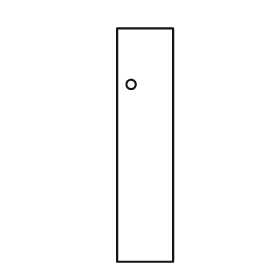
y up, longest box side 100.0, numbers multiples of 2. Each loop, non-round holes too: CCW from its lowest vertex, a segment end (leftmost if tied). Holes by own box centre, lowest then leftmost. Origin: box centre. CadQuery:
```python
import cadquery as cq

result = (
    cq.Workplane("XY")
    .moveTo(-12.0, -50.0)
    .lineTo(12.0, -50.0)
    .lineTo(12.0, 50.0)
    .lineTo(-12.0, 50.0)
    .close()
    .moveTo(-6.0, 26.0)
    .circle(2.0)
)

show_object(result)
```